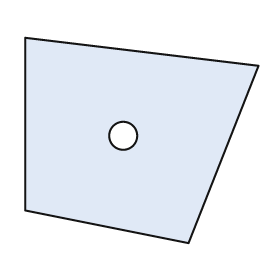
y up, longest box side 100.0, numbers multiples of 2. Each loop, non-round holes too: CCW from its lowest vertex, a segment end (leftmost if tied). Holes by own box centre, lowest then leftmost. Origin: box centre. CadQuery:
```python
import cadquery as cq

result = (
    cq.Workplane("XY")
    .moveTo(20.0, -44.0)
    .lineTo(50.0, 32.0)
    .lineTo(-50.0, 44.0)
    .lineTo(-50.0, -30.0)
    .close()
    .moveTo(-8.0, 2.0)
    .circle(6.0)
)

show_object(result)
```